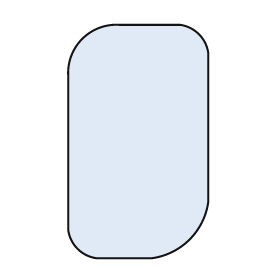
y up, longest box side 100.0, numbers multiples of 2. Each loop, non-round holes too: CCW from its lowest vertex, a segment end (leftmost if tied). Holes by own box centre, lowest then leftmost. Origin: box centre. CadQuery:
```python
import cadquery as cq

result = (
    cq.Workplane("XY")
    .moveTo(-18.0, -50.0)
    .lineTo(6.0, -50.0)
    .threePointArc((22.0, -42.0), (30.0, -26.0))
    .lineTo(30.0, 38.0)
    .threePointArc((26.0, 46.0), (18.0, 50.0))
    .lineTo(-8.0, 50.0)
    .threePointArc((-24.0, 44.0), (-30.0, 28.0))
    .lineTo(-30.0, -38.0)
    .threePointArc((-26.0, -46.0), (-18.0, -50.0))
    .close()
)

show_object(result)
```